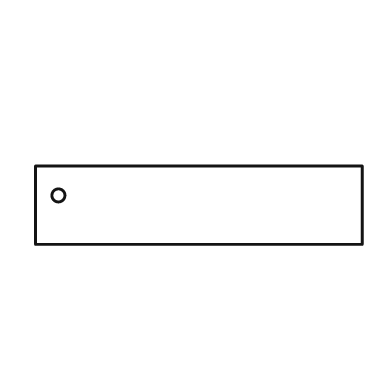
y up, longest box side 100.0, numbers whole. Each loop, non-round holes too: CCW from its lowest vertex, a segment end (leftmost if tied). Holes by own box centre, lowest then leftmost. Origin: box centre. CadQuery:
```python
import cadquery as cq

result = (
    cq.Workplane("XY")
    .moveTo(-50.0, -12.0)
    .lineTo(50.0, -12.0)
    .lineTo(50.0, 12.0)
    .lineTo(-50.0, 12.0)
    .close()
    .moveTo(-43.0, 3.0)
    .circle(2.0)
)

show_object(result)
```